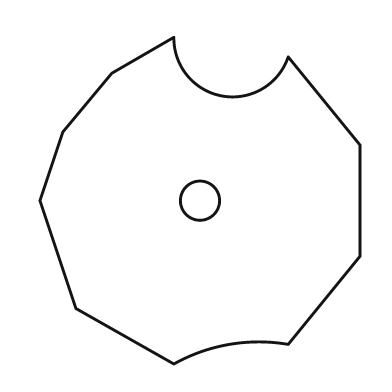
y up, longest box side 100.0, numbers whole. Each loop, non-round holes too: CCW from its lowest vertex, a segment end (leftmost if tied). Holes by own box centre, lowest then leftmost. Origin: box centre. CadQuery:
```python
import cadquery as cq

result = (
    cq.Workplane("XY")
    .moveTo(-8.0, -50.0)
    .threePointArc((9.0, -44.0), (27.0, -44.0))
    .lineTo(49.0, -17.0)
    .lineTo(49.0, 17.0)
    .lineTo(27.0, 44.0)
    .threePointArc((7.0, 32.0), (-8.0, 50.0))
    .lineTo(-27.0, 39.0)
    .lineTo(-42.0, 21.0)
    .lineTo(-49.0, 0.0)
    .lineTo(-38.0, -33.0)
    .close()
    .moveTo(0.0, 0.0)
    .circle(6.0)
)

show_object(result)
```